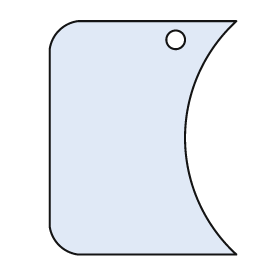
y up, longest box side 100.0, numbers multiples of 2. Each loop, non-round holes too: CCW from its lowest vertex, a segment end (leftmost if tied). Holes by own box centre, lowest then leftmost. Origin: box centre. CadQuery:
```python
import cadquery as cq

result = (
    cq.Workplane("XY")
    .moveTo(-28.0, -50.0)
    .lineTo(40.0, -50.0)
    .threePointArc((18.0, 0.0), (40.0, 50.0))
    .lineTo(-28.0, 50.0)
    .threePointArc((-36.0, 46.0), (-40.0, 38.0))
    .lineTo(-40.0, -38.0)
    .threePointArc((-36.0, -46.0), (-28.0, -50.0))
    .close()
    .moveTo(14.0, 42.0)
    .circle(4.0)
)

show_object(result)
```